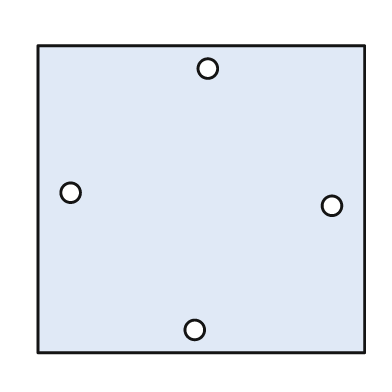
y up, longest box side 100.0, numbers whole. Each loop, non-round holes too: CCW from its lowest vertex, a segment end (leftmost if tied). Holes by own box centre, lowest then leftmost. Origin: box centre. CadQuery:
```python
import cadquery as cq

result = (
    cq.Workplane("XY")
    .moveTo(-50.0, -47.0)
    .lineTo(50.0, -47.0)
    .lineTo(50.0, 47.0)
    .lineTo(-50.0, 47.0)
    .close()
    .moveTo(-2.0, -40.0)
    .circle(3.0)
    .moveTo(40.0, -2.0)
    .circle(3.0)
    .moveTo(-40.0, 2.0)
    .circle(3.0)
    .moveTo(2.0, 40.0)
    .circle(3.0)
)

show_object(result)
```